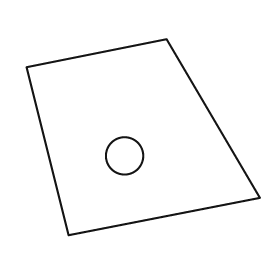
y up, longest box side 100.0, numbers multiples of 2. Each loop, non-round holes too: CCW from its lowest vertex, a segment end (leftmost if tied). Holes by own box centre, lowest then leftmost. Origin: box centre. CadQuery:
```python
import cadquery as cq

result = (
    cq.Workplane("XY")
    .moveTo(-32.0, -42.0)
    .lineTo(50.0, -26.0)
    .lineTo(10.0, 42.0)
    .lineTo(-50.0, 30.0)
    .close()
    .moveTo(-8.0, -8.0)
    .circle(8.0)
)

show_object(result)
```